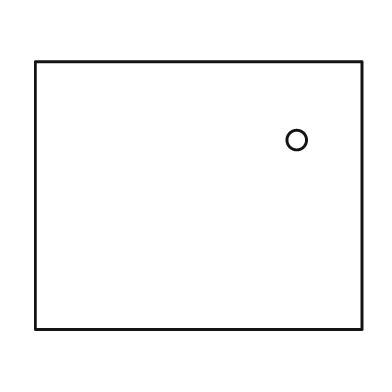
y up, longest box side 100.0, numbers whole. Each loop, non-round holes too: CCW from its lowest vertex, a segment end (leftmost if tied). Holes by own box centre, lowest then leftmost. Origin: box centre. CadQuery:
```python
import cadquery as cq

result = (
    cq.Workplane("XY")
    .moveTo(-50.0, -41.0)
    .lineTo(50.0, -41.0)
    .lineTo(50.0, 41.0)
    .lineTo(-50.0, 41.0)
    .close()
    .moveTo(30.0, 17.0)
    .circle(3.0)
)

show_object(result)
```